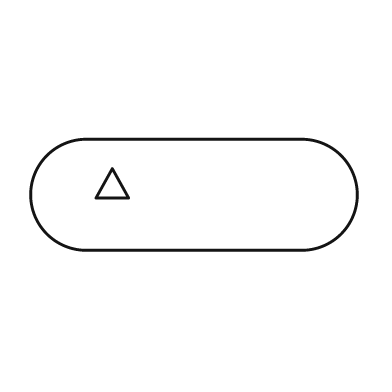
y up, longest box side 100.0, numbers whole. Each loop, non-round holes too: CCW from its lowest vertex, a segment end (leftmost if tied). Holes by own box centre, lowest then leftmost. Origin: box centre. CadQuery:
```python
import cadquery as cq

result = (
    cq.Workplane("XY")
    .moveTo(-33.0, -17.0)
    .lineTo(33.0, -17.0)
    .threePointArc((50.0, 0.0), (33.0, 17.0))
    .lineTo(-33.0, 17.0)
    .threePointArc((-50.0, 0.0), (-33.0, -17.0))
    .close()
    .moveTo(-30.0, -1.0)
    .lineTo(-20.0, -1.0)
    .lineTo(-25.0, 8.0)
    .close()
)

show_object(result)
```